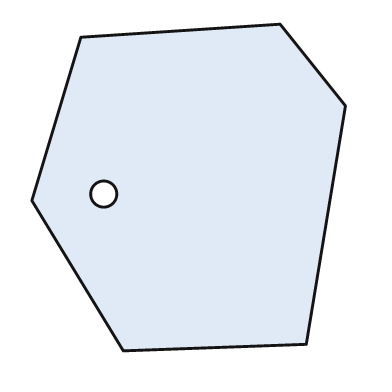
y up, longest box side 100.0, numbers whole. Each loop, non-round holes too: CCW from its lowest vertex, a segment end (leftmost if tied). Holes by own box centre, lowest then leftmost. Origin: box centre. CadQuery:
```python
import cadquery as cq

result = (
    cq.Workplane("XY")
    .moveTo(-20.0, -50.0)
    .lineTo(36.0, -48.0)
    .lineTo(48.0, 25.0)
    .lineTo(28.0, 50.0)
    .lineTo(-33.0, 46.0)
    .lineTo(-48.0, -4.0)
    .close()
    .moveTo(-26.0, -2.0)
    .circle(4.0)
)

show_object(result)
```